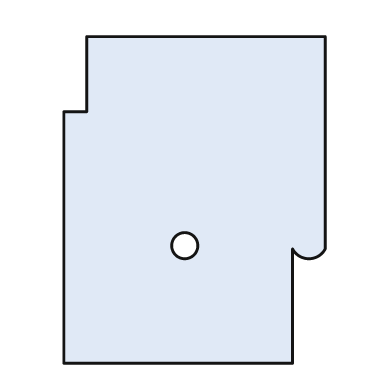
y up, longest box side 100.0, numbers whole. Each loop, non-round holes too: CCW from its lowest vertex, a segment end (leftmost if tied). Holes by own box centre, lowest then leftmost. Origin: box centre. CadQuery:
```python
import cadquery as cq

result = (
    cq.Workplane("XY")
    .moveTo(-40.0, -50.0)
    .lineTo(30.0, -50.0)
    .lineTo(30.0, -15.0)
    .threePointArc((35.0, -18.0), (40.0, -15.0))
    .lineTo(40.0, 50.0)
    .lineTo(-33.0, 50.0)
    .lineTo(-33.0, 27.0)
    .lineTo(-40.0, 27.0)
    .close()
    .moveTo(-3.0, -14.0)
    .circle(4.0)
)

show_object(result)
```